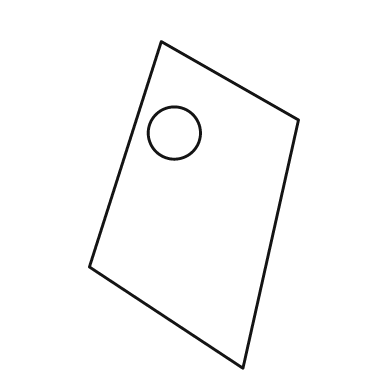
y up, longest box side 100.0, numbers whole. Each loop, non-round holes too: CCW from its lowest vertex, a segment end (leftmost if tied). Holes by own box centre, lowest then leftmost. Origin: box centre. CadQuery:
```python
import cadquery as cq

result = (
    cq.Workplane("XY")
    .moveTo(15.0, -50.0)
    .lineTo(32.0, 26.0)
    .lineTo(-10.0, 50.0)
    .lineTo(-32.0, -19.0)
    .close()
    .moveTo(-6.0, 22.0)
    .circle(8.0)
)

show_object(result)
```